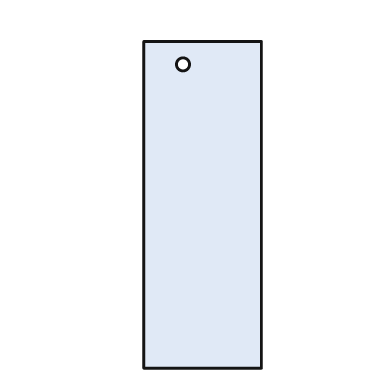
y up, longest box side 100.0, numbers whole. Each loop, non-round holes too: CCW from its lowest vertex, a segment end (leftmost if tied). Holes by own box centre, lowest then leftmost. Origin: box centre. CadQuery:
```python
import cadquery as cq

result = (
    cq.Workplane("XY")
    .moveTo(-18.0, -50.0)
    .lineTo(18.0, -50.0)
    .lineTo(18.0, 50.0)
    .lineTo(-18.0, 50.0)
    .close()
    .moveTo(-6.0, 43.0)
    .circle(2.0)
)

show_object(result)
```